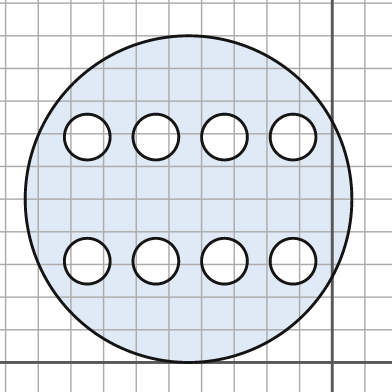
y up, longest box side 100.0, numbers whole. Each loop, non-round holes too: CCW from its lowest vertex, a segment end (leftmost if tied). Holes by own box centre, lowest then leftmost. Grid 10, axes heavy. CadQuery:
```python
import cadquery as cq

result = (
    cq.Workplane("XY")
    .moveTo(-44.0, 50.0)
    .circle(50.0)
    .moveTo(-75.0, 31.0)
    .circle(7.0)
    .moveTo(-54.0, 31.0)
    .circle(7.0)
    .moveTo(-33.0, 31.0)
    .circle(7.0)
    .moveTo(-12.0, 31.0)
    .circle(7.0)
    .moveTo(-75.0, 69.0)
    .circle(7.0)
    .moveTo(-54.0, 69.0)
    .circle(7.0)
    .moveTo(-33.0, 69.0)
    .circle(7.0)
    .moveTo(-12.0, 69.0)
    .circle(7.0)
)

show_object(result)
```